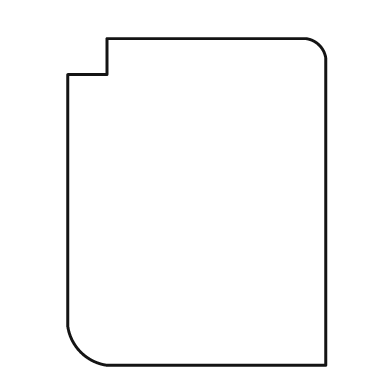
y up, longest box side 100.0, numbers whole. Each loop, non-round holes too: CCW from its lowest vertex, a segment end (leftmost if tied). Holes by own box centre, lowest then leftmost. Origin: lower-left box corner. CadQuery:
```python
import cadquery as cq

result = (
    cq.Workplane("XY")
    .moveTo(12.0, 0.0)
    .lineTo(79.0, 0.0)
    .lineTo(79.0, 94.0)
    .threePointArc((77.0, 98.0), (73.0, 100.0))
    .lineTo(12.0, 100.0)
    .lineTo(12.0, 89.0)
    .lineTo(0.0, 89.0)
    .lineTo(0.0, 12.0)
    .threePointArc((4.0, 4.0), (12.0, 0.0))
    .close()
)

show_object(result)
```